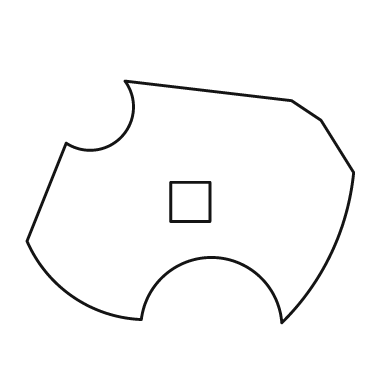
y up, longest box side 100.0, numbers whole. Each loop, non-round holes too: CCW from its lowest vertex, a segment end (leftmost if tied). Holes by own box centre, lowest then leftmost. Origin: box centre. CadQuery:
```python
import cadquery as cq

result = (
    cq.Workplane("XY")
    .moveTo(28.0, -37.0)
    .threePointArc((43.0, -16.0), (50.0, 9.0))
    .lineTo(40.0, 25.0)
    .lineTo(31.0, 31.0)
    .lineTo(-20.0, 37.0)
    .threePointArc((-21.0, 20.0), (-38.0, 18.0))
    .lineTo(-50.0, -12.0)
    .threePointArc((-36.0, -29.0), (-15.0, -36.0))
    .threePointArc((7.0, -17.0), (28.0, -37.0))
    .close()
    .moveTo(-6.0, -6.0)
    .lineTo(6.0, -6.0)
    .lineTo(6.0, 6.0)
    .lineTo(-6.0, 6.0)
    .close()
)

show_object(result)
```